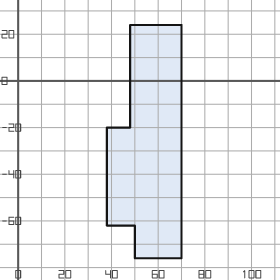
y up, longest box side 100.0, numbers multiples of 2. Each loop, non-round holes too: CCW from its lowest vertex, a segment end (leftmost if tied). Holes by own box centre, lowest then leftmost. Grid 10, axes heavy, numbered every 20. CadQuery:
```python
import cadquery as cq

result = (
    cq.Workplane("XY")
    .moveTo(50.0, -76.0)
    .lineTo(70.0, -76.0)
    .lineTo(70.0, 24.0)
    .lineTo(48.0, 24.0)
    .lineTo(48.0, -20.0)
    .lineTo(38.0, -20.0)
    .lineTo(38.0, -62.0)
    .lineTo(50.0, -62.0)
    .close()
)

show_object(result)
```